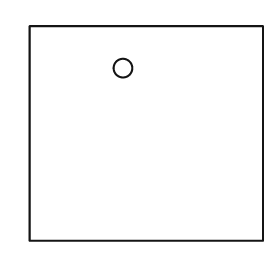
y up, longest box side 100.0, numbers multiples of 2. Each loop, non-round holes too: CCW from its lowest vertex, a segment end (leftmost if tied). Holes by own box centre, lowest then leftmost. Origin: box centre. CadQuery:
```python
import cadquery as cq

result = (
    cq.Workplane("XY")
    .moveTo(-50.0, -46.0)
    .lineTo(50.0, -46.0)
    .lineTo(50.0, 46.0)
    .lineTo(-50.0, 46.0)
    .close()
    .moveTo(-10.0, 28.0)
    .circle(4.0)
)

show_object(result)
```